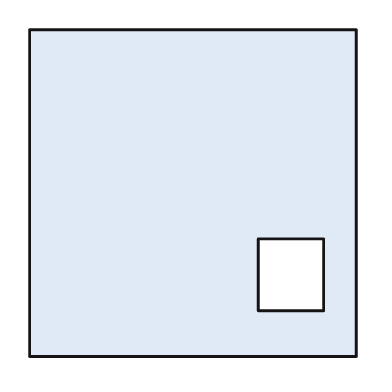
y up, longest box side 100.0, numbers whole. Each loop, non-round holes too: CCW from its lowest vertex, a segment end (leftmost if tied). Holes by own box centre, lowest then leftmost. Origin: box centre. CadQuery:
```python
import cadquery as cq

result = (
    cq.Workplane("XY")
    .moveTo(-50.0, -50.0)
    .lineTo(50.0, -50.0)
    .lineTo(50.0, 50.0)
    .lineTo(-50.0, 50.0)
    .close()
    .moveTo(20.0, -36.0)
    .lineTo(40.0, -36.0)
    .lineTo(40.0, -14.0)
    .lineTo(20.0, -14.0)
    .close()
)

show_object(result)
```